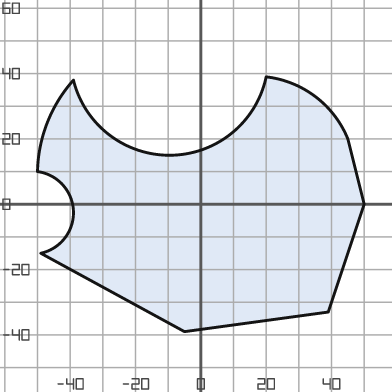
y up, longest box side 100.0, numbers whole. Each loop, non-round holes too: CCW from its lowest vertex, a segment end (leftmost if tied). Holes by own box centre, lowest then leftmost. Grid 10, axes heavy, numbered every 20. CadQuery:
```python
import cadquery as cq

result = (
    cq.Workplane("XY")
    .moveTo(-5.0, -39.0)
    .lineTo(39.0, -33.0)
    .lineTo(50.0, 0.0)
    .lineTo(45.0, 20.0)
    .threePointArc((35.0, 33.0), (20.0, 39.0))
    .threePointArc((-9.0, 15.0), (-39.0, 38.0))
    .threePointArc((-47.0, 25.0), (-50.0, 10.0))
    .threePointArc((-39.0, -2.0), (-49.0, -15.0))
    .close()
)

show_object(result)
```